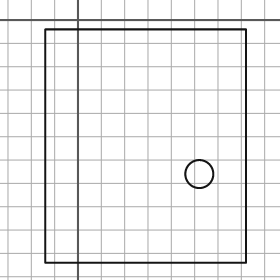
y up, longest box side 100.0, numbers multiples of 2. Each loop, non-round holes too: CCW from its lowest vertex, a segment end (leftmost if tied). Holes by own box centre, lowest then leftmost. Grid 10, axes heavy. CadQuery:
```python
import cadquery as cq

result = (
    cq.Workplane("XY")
    .moveTo(-14.0, -104.0)
    .lineTo(72.0, -104.0)
    .lineTo(72.0, -4.0)
    .lineTo(-14.0, -4.0)
    .close()
    .moveTo(52.0, -66.0)
    .circle(6.0)
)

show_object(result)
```